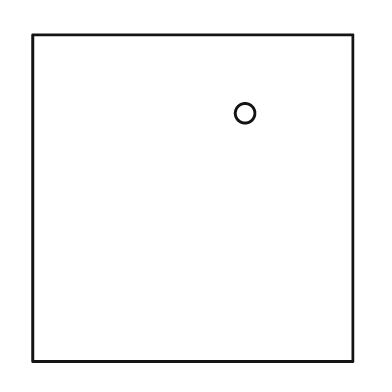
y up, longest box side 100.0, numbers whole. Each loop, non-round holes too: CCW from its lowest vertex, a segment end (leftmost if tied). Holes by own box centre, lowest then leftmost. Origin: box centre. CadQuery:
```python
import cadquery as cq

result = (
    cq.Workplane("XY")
    .moveTo(-49.0, -50.0)
    .lineTo(49.0, -50.0)
    .lineTo(49.0, 50.0)
    .lineTo(-49.0, 50.0)
    .close()
    .moveTo(16.0, 26.0)
    .circle(3.0)
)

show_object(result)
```